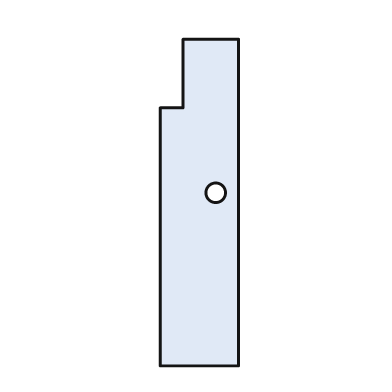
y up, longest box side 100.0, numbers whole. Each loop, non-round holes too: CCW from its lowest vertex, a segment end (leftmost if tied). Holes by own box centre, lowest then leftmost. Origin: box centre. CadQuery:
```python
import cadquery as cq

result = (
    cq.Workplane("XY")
    .moveTo(-12.0, -50.0)
    .lineTo(12.0, -50.0)
    .lineTo(12.0, 50.0)
    .lineTo(-5.0, 50.0)
    .lineTo(-5.0, 29.0)
    .lineTo(-12.0, 29.0)
    .close()
    .moveTo(5.0, 3.0)
    .circle(3.0)
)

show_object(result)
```